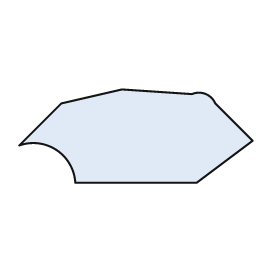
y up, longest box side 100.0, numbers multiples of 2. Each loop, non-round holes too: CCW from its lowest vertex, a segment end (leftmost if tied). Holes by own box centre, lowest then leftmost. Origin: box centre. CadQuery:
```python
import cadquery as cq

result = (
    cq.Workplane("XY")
    .moveTo(-26.0, -20.0)
    .lineTo(26.0, -20.0)
    .lineTo(50.0, -2.0)
    .lineTo(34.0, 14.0)
    .threePointArc((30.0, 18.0), (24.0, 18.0))
    .lineTo(-6.0, 20.0)
    .lineTo(-32.0, 14.0)
    .lineTo(-50.0, -4.0)
    .threePointArc((-34.0, -6.0), (-26.0, -20.0))
    .close()
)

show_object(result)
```